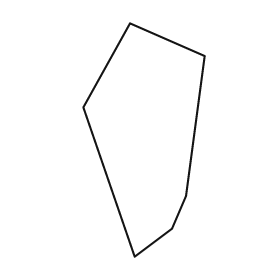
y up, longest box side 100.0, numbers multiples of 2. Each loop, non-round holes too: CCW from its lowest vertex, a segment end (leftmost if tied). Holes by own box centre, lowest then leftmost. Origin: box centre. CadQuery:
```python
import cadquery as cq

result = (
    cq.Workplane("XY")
    .moveTo(-4.0, -50.0)
    .lineTo(12.0, -38.0)
    .lineTo(18.0, -24.0)
    .lineTo(26.0, 36.0)
    .lineTo(-6.0, 50.0)
    .lineTo(-26.0, 14.0)
    .close()
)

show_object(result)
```